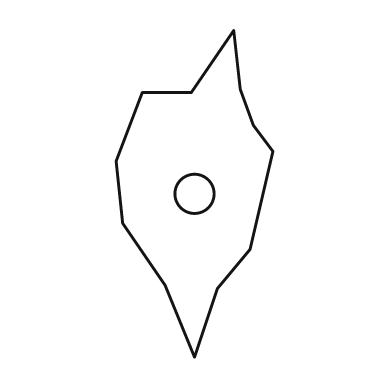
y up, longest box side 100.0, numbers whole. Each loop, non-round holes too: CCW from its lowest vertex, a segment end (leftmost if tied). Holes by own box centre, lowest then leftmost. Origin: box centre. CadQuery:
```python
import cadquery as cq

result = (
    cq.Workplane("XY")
    .moveTo(0.0, -50.0)
    .lineTo(7.0, -29.0)
    .lineTo(17.0, -17.0)
    .lineTo(24.0, 13.0)
    .lineTo(18.0, 21.0)
    .lineTo(14.0, 32.0)
    .lineTo(12.0, 50.0)
    .lineTo(-1.0, 31.0)
    .lineTo(-16.0, 31.0)
    .lineTo(-24.0, 10.0)
    .lineTo(-22.0, -9.0)
    .lineTo(-9.0, -28.0)
    .close()
    .moveTo(0.0, 0.0)
    .circle(6.0)
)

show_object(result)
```